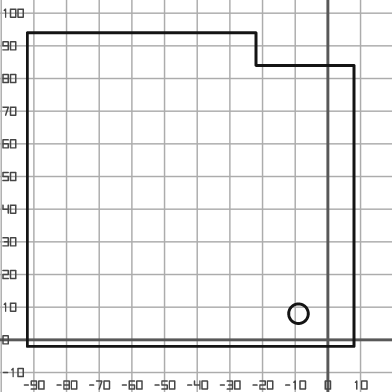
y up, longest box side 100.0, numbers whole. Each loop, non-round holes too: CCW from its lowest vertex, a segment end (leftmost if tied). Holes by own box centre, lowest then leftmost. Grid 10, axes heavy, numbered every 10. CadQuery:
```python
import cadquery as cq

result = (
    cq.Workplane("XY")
    .moveTo(-92.0, -2.0)
    .lineTo(8.0, -2.0)
    .lineTo(8.0, 84.0)
    .lineTo(-22.0, 84.0)
    .lineTo(-22.0, 94.0)
    .lineTo(-92.0, 94.0)
    .close()
    .moveTo(-9.0, 8.0)
    .circle(3.0)
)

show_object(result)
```